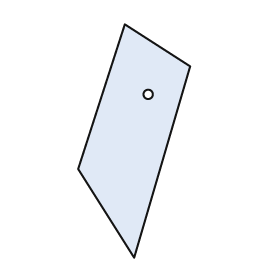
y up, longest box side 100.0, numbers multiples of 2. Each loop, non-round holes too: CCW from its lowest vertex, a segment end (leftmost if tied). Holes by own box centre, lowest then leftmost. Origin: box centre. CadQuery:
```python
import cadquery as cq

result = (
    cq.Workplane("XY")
    .moveTo(0.0, -50.0)
    .lineTo(24.0, 32.0)
    .lineTo(-4.0, 50.0)
    .lineTo(-24.0, -12.0)
    .close()
    .moveTo(6.0, 20.0)
    .circle(2.0)
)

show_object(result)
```